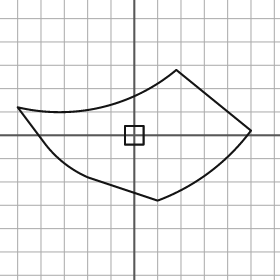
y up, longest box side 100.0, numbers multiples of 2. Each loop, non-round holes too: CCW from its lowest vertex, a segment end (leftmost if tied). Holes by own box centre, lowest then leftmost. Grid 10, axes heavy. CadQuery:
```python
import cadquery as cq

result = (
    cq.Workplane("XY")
    .moveTo(10.0, -28.0)
    .threePointArc((32.0, -16.0), (50.0, 2.0))
    .lineTo(18.0, 28.0)
    .threePointArc((-14.0, 12.0), (-50.0, 12.0))
    .lineTo(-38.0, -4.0)
    .threePointArc((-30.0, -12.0), (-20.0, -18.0))
    .close()
    .moveTo(-4.0, -4.0)
    .lineTo(4.0, -4.0)
    .lineTo(4.0, 4.0)
    .lineTo(-4.0, 4.0)
    .close()
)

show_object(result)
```